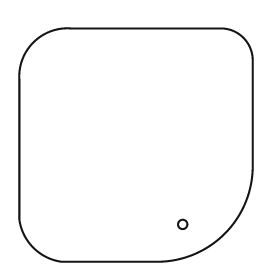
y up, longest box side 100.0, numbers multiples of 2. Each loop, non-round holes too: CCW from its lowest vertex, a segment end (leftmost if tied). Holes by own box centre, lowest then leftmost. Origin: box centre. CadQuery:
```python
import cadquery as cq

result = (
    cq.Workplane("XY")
    .moveTo(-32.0, -50.0)
    .lineTo(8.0, -50.0)
    .threePointArc((38.0, -38.0), (50.0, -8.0))
    .lineTo(50.0, 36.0)
    .threePointArc((46.0, 46.0), (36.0, 50.0))
    .lineTo(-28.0, 50.0)
    .threePointArc((-44.0, 44.0), (-50.0, 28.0))
    .lineTo(-50.0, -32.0)
    .threePointArc((-44.0, -44.0), (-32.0, -50.0))
    .close()
    .moveTo(20.0, -34.0)
    .circle(2.0)
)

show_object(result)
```